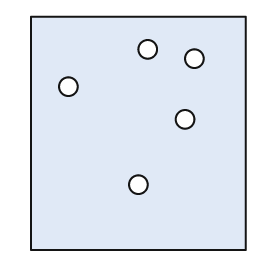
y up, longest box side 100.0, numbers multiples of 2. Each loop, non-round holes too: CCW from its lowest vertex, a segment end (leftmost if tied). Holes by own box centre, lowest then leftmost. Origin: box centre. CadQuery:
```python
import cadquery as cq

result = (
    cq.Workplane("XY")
    .moveTo(-46.0, -50.0)
    .lineTo(46.0, -50.0)
    .lineTo(46.0, 50.0)
    .lineTo(-46.0, 50.0)
    .close()
    .moveTo(0.0, -22.0)
    .circle(4.0)
    .moveTo(20.0, 6.0)
    .circle(4.0)
    .moveTo(-30.0, 20.0)
    .circle(4.0)
    .moveTo(24.0, 32.0)
    .circle(4.0)
    .moveTo(4.0, 36.0)
    .circle(4.0)
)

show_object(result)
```